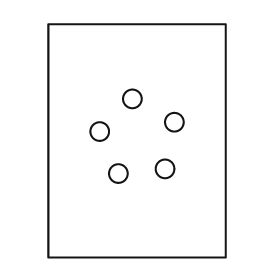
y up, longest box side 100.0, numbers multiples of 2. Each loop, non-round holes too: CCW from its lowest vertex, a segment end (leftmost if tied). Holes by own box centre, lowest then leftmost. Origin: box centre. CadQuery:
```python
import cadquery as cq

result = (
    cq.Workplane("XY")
    .moveTo(-38.0, -50.0)
    .lineTo(38.0, -50.0)
    .lineTo(38.0, 50.0)
    .lineTo(-38.0, 50.0)
    .close()
    .moveTo(-8.0, -14.0)
    .circle(4.0)
    .moveTo(12.0, -12.0)
    .circle(4.0)
    .moveTo(-16.0, 4.0)
    .circle(4.0)
    .moveTo(16.0, 8.0)
    .circle(4.0)
    .moveTo(-2.0, 18.0)
    .circle(4.0)
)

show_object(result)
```